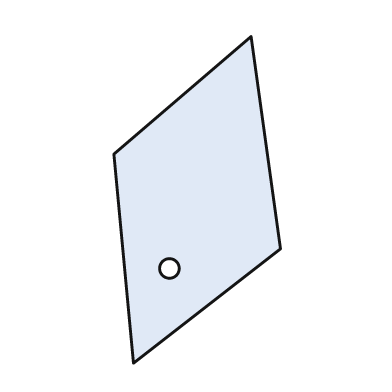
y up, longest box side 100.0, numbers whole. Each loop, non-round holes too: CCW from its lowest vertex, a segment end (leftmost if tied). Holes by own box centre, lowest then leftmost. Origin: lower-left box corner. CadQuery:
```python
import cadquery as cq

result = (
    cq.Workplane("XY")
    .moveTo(6.0, 0.0)
    .lineTo(51.0, 35.0)
    .lineTo(42.0, 100.0)
    .lineTo(0.0, 64.0)
    .close()
    .moveTo(17.0, 29.0)
    .circle(3.0)
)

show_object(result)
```